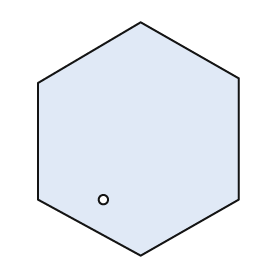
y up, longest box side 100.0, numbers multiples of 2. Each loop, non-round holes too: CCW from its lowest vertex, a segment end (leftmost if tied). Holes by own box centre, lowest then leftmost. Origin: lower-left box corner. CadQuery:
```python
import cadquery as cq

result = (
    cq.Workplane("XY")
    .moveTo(44.0, 0.0)
    .lineTo(86.0, 24.0)
    .lineTo(86.0, 76.0)
    .lineTo(44.0, 100.0)
    .lineTo(0.0, 74.0)
    .lineTo(0.0, 24.0)
    .close()
    .moveTo(28.0, 24.0)
    .circle(2.0)
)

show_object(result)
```